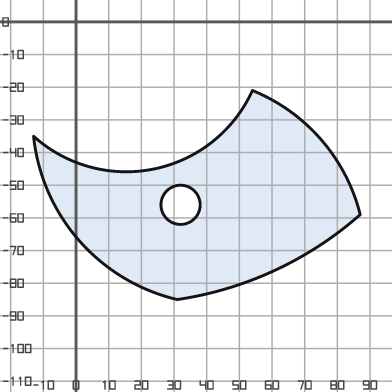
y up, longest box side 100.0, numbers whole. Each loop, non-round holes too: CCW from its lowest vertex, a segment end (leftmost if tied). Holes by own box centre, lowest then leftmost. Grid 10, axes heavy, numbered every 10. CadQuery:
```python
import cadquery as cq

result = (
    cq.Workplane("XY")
    .moveTo(31.0, -85.0)
    .threePointArc((61.0, -76.0), (87.0, -59.0))
    .threePointArc((75.0, -36.0), (54.0, -21.0))
    .threePointArc((24.0, -45.0), (-13.0, -35.0))
    .threePointArc((1.0, -67.0), (31.0, -85.0))
    .close()
    .moveTo(32.0, -56.0)
    .circle(6.0)
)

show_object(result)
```